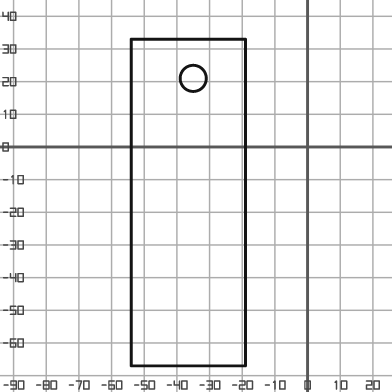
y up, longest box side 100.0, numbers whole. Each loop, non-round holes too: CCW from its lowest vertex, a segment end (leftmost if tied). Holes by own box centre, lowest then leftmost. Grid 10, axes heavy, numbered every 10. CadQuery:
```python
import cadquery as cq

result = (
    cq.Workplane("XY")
    .moveTo(-54.0, -67.0)
    .lineTo(-19.0, -67.0)
    .lineTo(-19.0, 33.0)
    .lineTo(-54.0, 33.0)
    .close()
    .moveTo(-35.0, 21.0)
    .circle(4.0)
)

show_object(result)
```